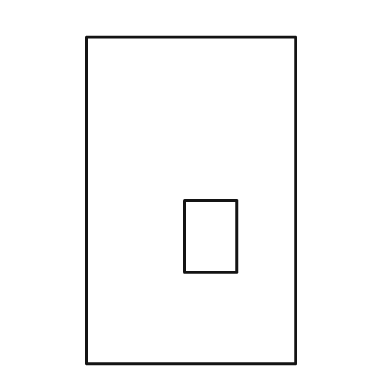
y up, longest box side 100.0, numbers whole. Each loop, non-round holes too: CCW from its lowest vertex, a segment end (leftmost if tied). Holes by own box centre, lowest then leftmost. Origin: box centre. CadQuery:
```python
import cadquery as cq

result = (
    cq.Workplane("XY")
    .moveTo(-32.0, -50.0)
    .lineTo(32.0, -50.0)
    .lineTo(32.0, 50.0)
    .lineTo(-32.0, 50.0)
    .close()
    .moveTo(-2.0, -22.0)
    .lineTo(14.0, -22.0)
    .lineTo(14.0, 0.0)
    .lineTo(-2.0, 0.0)
    .close()
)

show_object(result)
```